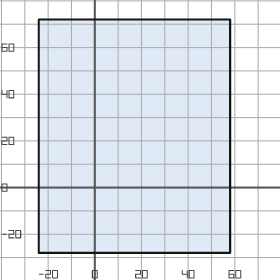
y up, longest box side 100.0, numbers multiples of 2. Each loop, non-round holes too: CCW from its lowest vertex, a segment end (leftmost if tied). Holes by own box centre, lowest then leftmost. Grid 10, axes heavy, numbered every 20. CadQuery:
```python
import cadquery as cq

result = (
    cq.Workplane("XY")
    .moveTo(-24.0, -28.0)
    .lineTo(58.0, -28.0)
    .lineTo(58.0, 72.0)
    .lineTo(-24.0, 72.0)
    .close()
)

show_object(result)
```